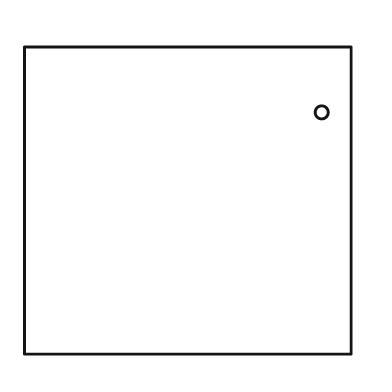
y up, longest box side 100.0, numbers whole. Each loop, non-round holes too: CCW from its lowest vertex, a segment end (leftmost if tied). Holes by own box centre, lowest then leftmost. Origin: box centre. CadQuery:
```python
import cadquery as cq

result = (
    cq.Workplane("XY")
    .moveTo(-50.0, -47.0)
    .lineTo(50.0, -47.0)
    .lineTo(50.0, 47.0)
    .lineTo(-50.0, 47.0)
    .close()
    .moveTo(41.0, 27.0)
    .circle(2.0)
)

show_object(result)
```